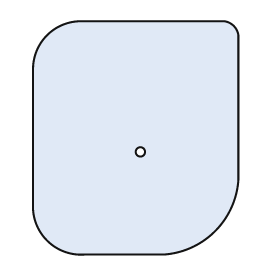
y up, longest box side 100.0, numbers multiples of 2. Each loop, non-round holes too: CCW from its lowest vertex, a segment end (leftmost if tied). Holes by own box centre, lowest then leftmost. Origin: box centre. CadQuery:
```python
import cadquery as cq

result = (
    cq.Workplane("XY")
    .moveTo(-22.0, -50.0)
    .lineTo(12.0, -50.0)
    .threePointArc((34.0, -40.0), (44.0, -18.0))
    .lineTo(44.0, 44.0)
    .threePointArc((42.0, 48.0), (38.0, 50.0))
    .lineTo(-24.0, 50.0)
    .threePointArc((-38.0, 44.0), (-44.0, 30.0))
    .lineTo(-44.0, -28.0)
    .threePointArc((-38.0, -44.0), (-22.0, -50.0))
    .close()
    .moveTo(2.0, -6.0)
    .circle(2.0)
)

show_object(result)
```